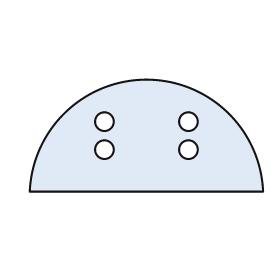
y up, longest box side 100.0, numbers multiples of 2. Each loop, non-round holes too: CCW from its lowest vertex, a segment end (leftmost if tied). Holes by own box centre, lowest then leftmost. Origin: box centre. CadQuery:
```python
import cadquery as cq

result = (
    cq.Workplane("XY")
    .moveTo(-50.0, -24.0)
    .lineTo(50.0, -24.0)
    .threePointArc((0.0, 24.0), (-50.0, -24.0))
    .close()
    .moveTo(-18.0, -6.0)
    .circle(4.0)
    .moveTo(18.0, -6.0)
    .circle(4.0)
    .moveTo(-18.0, 6.0)
    .circle(4.0)
    .moveTo(18.0, 6.0)
    .circle(4.0)
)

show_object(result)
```